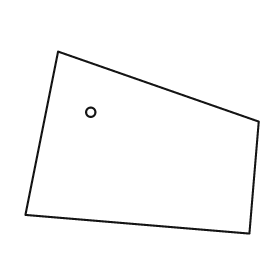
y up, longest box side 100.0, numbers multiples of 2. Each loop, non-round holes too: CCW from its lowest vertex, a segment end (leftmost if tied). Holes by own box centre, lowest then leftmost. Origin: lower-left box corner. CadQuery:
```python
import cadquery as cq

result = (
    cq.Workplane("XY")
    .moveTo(96.0, 0.0)
    .lineTo(100.0, 48.0)
    .lineTo(14.0, 78.0)
    .lineTo(0.0, 8.0)
    .close()
    .moveTo(28.0, 52.0)
    .circle(2.0)
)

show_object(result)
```